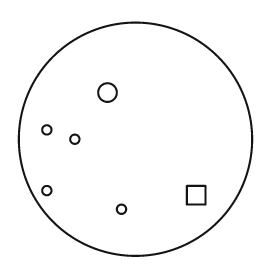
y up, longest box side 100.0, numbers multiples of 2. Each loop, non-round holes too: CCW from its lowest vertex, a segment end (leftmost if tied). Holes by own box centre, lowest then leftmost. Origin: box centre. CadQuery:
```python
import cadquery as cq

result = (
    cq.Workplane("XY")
    .moveTo(0.0, 0.0)
    .circle(50.0)
    .moveTo(-6.0, -30.0)
    .circle(2.0)
    .moveTo(22.0, -28.0)
    .lineTo(30.0, -28.0)
    .lineTo(30.0, -20.0)
    .lineTo(22.0, -20.0)
    .close()
    .moveTo(-38.0, -22.0)
    .circle(2.0)
    .moveTo(-26.0, 0.0)
    .circle(2.0)
    .moveTo(-38.0, 4.0)
    .circle(2.0)
    .moveTo(-12.0, 20.0)
    .circle(4.0)
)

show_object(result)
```